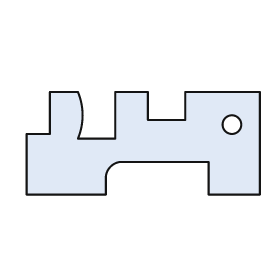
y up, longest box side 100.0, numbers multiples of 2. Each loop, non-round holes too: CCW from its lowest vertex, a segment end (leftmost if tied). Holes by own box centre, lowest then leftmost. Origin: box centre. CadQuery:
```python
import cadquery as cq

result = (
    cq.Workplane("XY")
    .moveTo(-50.0, -22.0)
    .lineTo(-16.0, -22.0)
    .lineTo(-16.0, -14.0)
    .threePointArc((-14.0, -10.0), (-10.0, -8.0))
    .lineTo(28.0, -8.0)
    .lineTo(28.0, -22.0)
    .lineTo(50.0, -22.0)
    .lineTo(50.0, 22.0)
    .lineTo(18.0, 22.0)
    .lineTo(18.0, 10.0)
    .lineTo(2.0, 10.0)
    .lineTo(2.0, 22.0)
    .lineTo(-12.0, 22.0)
    .lineTo(-12.0, 2.0)
    .lineTo(-28.0, 2.0)
    .threePointArc((-26.0, 12.0), (-28.0, 22.0))
    .lineTo(-40.0, 22.0)
    .lineTo(-40.0, 4.0)
    .lineTo(-50.0, 4.0)
    .close()
    .moveTo(38.0, 8.0)
    .circle(4.0)
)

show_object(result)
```